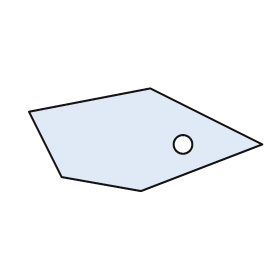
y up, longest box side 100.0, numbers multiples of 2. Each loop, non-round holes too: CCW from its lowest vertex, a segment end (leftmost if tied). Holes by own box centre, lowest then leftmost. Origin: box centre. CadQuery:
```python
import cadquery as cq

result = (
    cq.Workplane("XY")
    .moveTo(-2.0, -22.0)
    .lineTo(50.0, -2.0)
    .lineTo(2.0, 22.0)
    .lineTo(-50.0, 12.0)
    .lineTo(-36.0, -16.0)
    .close()
    .moveTo(16.0, -2.0)
    .circle(4.0)
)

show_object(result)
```